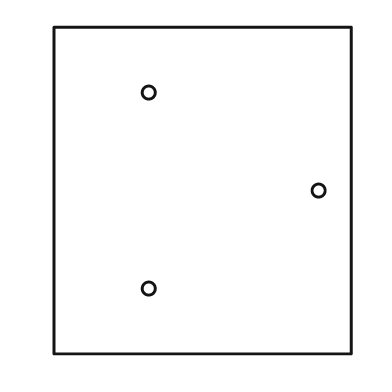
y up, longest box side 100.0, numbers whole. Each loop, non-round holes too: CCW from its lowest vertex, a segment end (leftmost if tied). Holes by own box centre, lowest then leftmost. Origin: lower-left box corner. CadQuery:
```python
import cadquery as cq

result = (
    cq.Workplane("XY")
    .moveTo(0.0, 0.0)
    .lineTo(91.0, 0.0)
    .lineTo(91.0, 100.0)
    .lineTo(0.0, 100.0)
    .close()
    .moveTo(29.0, 20.0)
    .circle(2.0)
    .moveTo(81.0, 50.0)
    .circle(2.0)
    .moveTo(29.0, 80.0)
    .circle(2.0)
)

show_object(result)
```